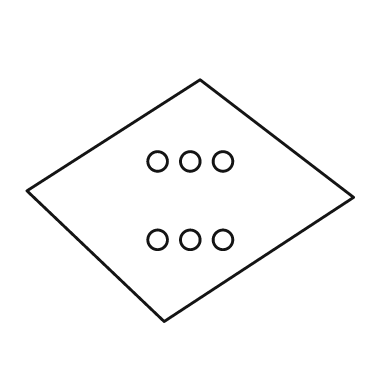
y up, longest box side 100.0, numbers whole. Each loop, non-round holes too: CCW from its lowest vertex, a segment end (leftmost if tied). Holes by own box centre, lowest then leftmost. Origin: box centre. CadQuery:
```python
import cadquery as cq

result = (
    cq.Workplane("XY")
    .moveTo(-8.0, -37.0)
    .lineTo(50.0, 1.0)
    .lineTo(3.0, 37.0)
    .lineTo(-50.0, 3.0)
    .close()
    .moveTo(-10.0, -12.0)
    .circle(3.0)
    .moveTo(0.0, -12.0)
    .circle(3.0)
    .moveTo(10.0, -12.0)
    .circle(3.0)
    .moveTo(-10.0, 12.0)
    .circle(3.0)
    .moveTo(0.0, 12.0)
    .circle(3.0)
    .moveTo(10.0, 12.0)
    .circle(3.0)
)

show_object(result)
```